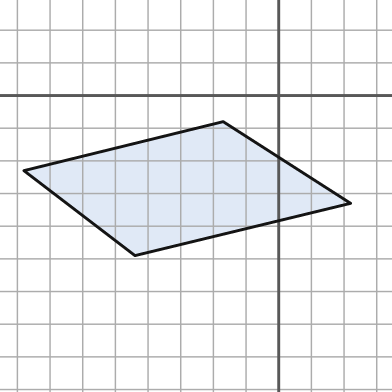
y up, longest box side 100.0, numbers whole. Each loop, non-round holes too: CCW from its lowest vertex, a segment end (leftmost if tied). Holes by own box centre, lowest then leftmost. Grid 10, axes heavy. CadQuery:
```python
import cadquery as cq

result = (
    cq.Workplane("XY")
    .moveTo(-44.0, -49.0)
    .lineTo(22.0, -33.0)
    .lineTo(-17.0, -8.0)
    .lineTo(-78.0, -23.0)
    .close()
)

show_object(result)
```